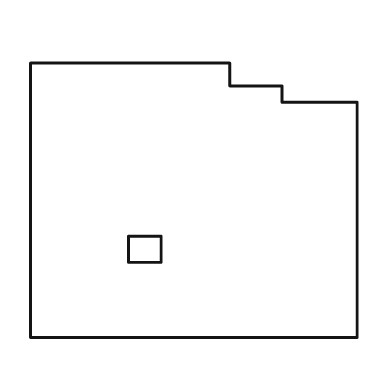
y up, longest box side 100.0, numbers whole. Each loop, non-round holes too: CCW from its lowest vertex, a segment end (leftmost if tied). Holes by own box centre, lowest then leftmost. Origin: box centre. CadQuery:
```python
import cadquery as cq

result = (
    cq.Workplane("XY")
    .moveTo(-50.0, -42.0)
    .lineTo(50.0, -42.0)
    .lineTo(50.0, 30.0)
    .lineTo(27.0, 30.0)
    .lineTo(27.0, 35.0)
    .lineTo(11.0, 35.0)
    .lineTo(11.0, 42.0)
    .lineTo(-50.0, 42.0)
    .close()
    .moveTo(-20.0, -19.0)
    .lineTo(-10.0, -19.0)
    .lineTo(-10.0, -11.0)
    .lineTo(-20.0, -11.0)
    .close()
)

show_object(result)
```